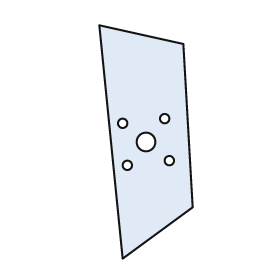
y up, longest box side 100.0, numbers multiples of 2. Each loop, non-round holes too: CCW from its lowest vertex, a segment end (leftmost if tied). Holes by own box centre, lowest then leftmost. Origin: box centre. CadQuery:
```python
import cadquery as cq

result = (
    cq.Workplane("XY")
    .moveTo(-10.0, -50.0)
    .lineTo(20.0, -28.0)
    .lineTo(16.0, 42.0)
    .lineTo(-20.0, 50.0)
    .close()
    .moveTo(-8.0, -10.0)
    .circle(2.0)
    .moveTo(10.0, -8.0)
    .circle(2.0)
    .moveTo(0.0, 0.0)
    .circle(4.0)
    .moveTo(-10.0, 8.0)
    .circle(2.0)
    .moveTo(8.0, 10.0)
    .circle(2.0)
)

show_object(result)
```